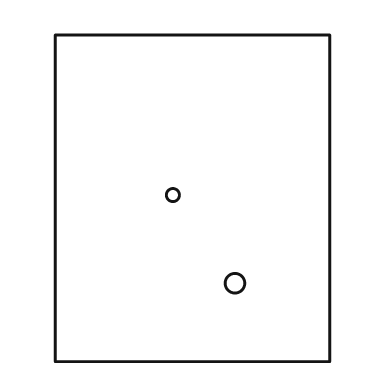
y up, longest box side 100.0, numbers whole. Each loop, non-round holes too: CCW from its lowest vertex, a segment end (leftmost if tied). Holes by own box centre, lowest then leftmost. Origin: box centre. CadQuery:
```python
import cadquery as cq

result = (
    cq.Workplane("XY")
    .moveTo(-42.0, -50.0)
    .lineTo(42.0, -50.0)
    .lineTo(42.0, 50.0)
    .lineTo(-42.0, 50.0)
    .close()
    .moveTo(13.0, -26.0)
    .circle(3.0)
    .moveTo(-6.0, 1.0)
    .circle(2.0)
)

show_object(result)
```